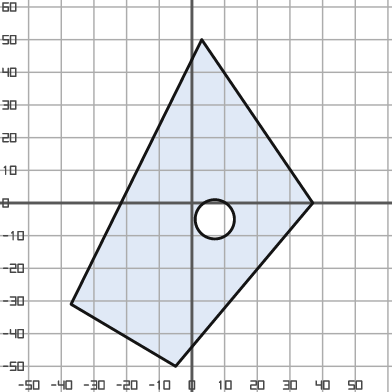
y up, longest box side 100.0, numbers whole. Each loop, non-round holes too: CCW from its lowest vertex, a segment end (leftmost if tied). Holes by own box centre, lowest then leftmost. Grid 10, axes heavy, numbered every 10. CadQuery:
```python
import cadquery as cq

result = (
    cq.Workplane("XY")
    .moveTo(-5.0, -50.0)
    .lineTo(37.0, 0.0)
    .lineTo(3.0, 50.0)
    .lineTo(-37.0, -31.0)
    .close()
    .moveTo(7.0, -5.0)
    .circle(6.0)
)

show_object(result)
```